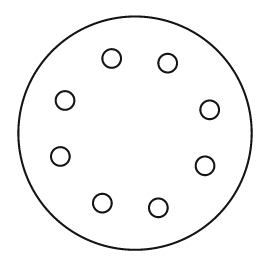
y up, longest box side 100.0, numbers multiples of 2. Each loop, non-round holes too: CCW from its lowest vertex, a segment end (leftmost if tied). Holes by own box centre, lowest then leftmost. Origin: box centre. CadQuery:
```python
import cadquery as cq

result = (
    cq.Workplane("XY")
    .moveTo(0.0, 0.0)
    .circle(50.0)
    .moveTo(10.0, -32.0)
    .circle(4.0)
    .moveTo(-14.0, -30.0)
    .circle(4.0)
    .moveTo(30.0, -14.0)
    .circle(4.0)
    .moveTo(-32.0, -10.0)
    .circle(4.0)
    .moveTo(32.0, 10.0)
    .circle(4.0)
    .moveTo(-30.0, 14.0)
    .circle(4.0)
    .moveTo(14.0, 30.0)
    .circle(4.0)
    .moveTo(-10.0, 32.0)
    .circle(4.0)
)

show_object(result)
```